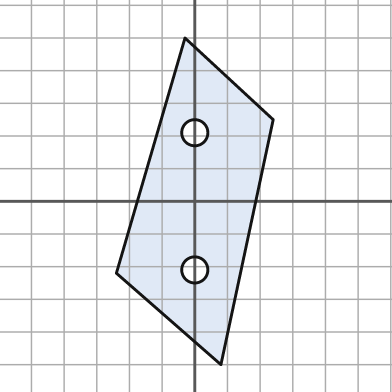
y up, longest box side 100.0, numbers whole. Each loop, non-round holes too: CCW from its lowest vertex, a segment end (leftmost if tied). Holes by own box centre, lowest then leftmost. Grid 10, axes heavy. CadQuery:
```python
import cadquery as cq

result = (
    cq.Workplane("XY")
    .moveTo(8.0, -50.0)
    .lineTo(24.0, 25.0)
    .lineTo(-3.0, 50.0)
    .lineTo(-24.0, -22.0)
    .close()
    .moveTo(0.0, -21.0)
    .circle(4.0)
    .moveTo(0.0, 21.0)
    .circle(4.0)
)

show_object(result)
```